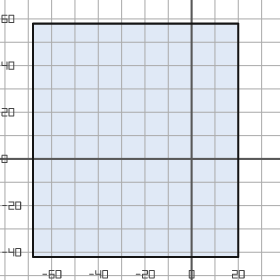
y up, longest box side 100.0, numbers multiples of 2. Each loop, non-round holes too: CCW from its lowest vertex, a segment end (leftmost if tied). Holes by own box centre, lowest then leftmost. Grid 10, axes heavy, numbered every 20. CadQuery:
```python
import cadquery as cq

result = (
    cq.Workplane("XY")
    .moveTo(-68.0, -42.0)
    .lineTo(20.0, -42.0)
    .lineTo(20.0, 58.0)
    .lineTo(-68.0, 58.0)
    .close()
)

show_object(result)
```